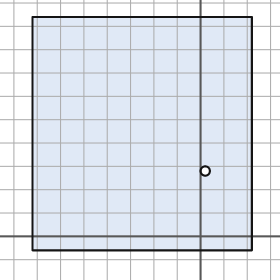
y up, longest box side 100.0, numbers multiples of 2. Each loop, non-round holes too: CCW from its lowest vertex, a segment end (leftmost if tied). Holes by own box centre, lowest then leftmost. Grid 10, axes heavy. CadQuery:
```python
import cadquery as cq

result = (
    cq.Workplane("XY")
    .moveTo(-72.0, -6.0)
    .lineTo(22.0, -6.0)
    .lineTo(22.0, 94.0)
    .lineTo(-72.0, 94.0)
    .close()
    .moveTo(2.0, 28.0)
    .circle(2.0)
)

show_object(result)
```